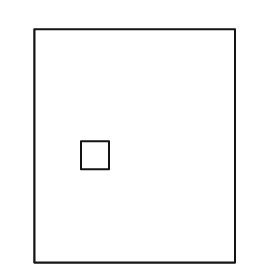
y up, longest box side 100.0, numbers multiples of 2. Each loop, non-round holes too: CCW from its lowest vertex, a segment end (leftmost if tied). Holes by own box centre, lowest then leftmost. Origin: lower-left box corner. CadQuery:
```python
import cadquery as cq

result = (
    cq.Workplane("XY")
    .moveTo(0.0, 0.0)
    .lineTo(86.0, 0.0)
    .lineTo(86.0, 100.0)
    .lineTo(0.0, 100.0)
    .close()
    .moveTo(20.0, 40.0)
    .lineTo(32.0, 40.0)
    .lineTo(32.0, 52.0)
    .lineTo(20.0, 52.0)
    .close()
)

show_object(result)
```